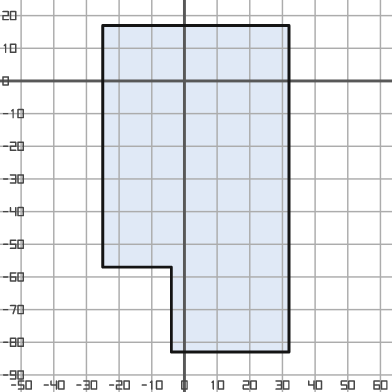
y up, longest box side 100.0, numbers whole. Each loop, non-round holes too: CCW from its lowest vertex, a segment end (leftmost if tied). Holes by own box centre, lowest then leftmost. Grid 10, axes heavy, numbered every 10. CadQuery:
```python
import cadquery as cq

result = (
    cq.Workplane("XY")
    .moveTo(-4.0, -83.0)
    .lineTo(32.0, -83.0)
    .lineTo(32.0, 17.0)
    .lineTo(-25.0, 17.0)
    .lineTo(-25.0, -57.0)
    .lineTo(-4.0, -57.0)
    .close()
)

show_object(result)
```